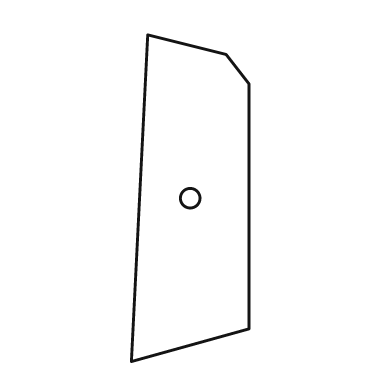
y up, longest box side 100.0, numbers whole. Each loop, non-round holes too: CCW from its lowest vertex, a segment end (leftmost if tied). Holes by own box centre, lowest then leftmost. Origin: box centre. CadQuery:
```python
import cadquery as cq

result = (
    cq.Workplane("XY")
    .moveTo(-18.0, -50.0)
    .lineTo(18.0, -40.0)
    .lineTo(18.0, 35.0)
    .lineTo(11.0, 44.0)
    .lineTo(-13.0, 50.0)
    .close()
    .moveTo(0.0, 0.0)
    .circle(3.0)
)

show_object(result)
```